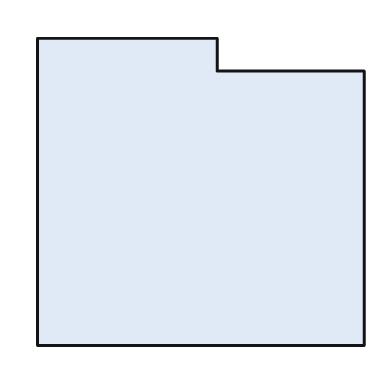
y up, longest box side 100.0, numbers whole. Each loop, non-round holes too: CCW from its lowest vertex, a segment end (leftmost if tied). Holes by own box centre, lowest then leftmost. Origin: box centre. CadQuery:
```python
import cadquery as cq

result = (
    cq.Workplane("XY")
    .moveTo(-50.0, -47.0)
    .lineTo(50.0, -47.0)
    .lineTo(50.0, 37.0)
    .lineTo(5.0, 37.0)
    .lineTo(5.0, 47.0)
    .lineTo(-50.0, 47.0)
    .close()
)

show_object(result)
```